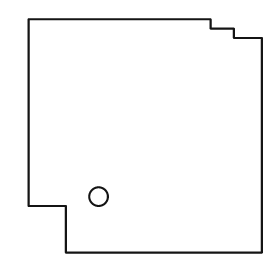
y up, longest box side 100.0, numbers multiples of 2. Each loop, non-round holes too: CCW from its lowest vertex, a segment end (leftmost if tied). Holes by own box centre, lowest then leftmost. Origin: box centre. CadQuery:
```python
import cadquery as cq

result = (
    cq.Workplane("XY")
    .moveTo(-34.0, -50.0)
    .lineTo(50.0, -50.0)
    .lineTo(50.0, 42.0)
    .lineTo(38.0, 42.0)
    .lineTo(38.0, 46.0)
    .lineTo(28.0, 46.0)
    .lineTo(28.0, 50.0)
    .lineTo(-50.0, 50.0)
    .lineTo(-50.0, -30.0)
    .lineTo(-34.0, -30.0)
    .close()
    .moveTo(-20.0, -26.0)
    .circle(4.0)
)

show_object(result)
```